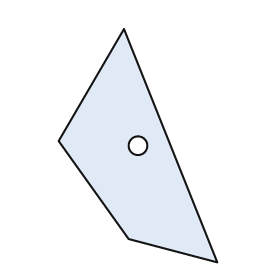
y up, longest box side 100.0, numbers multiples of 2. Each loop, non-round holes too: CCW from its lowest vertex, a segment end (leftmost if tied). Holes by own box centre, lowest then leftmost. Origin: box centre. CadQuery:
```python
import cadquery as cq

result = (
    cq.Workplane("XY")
    .moveTo(34.0, -50.0)
    .lineTo(-6.0, 50.0)
    .lineTo(-34.0, 2.0)
    .lineTo(-4.0, -40.0)
    .close()
    .moveTo(0.0, 0.0)
    .circle(4.0)
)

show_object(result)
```